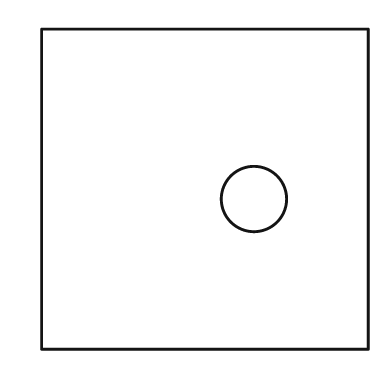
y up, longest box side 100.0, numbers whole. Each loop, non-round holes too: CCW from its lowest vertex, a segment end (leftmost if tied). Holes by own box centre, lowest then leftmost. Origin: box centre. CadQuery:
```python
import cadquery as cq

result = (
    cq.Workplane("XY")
    .moveTo(-50.0, -49.0)
    .lineTo(50.0, -49.0)
    .lineTo(50.0, 49.0)
    .lineTo(-50.0, 49.0)
    .close()
    .moveTo(15.0, -3.0)
    .circle(10.0)
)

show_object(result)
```